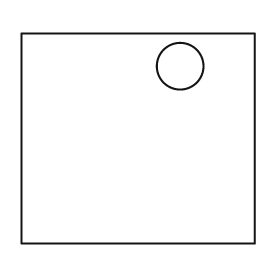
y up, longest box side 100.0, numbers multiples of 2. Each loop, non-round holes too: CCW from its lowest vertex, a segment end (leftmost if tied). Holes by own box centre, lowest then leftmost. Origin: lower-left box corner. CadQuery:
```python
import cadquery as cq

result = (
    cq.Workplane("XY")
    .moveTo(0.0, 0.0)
    .lineTo(100.0, 0.0)
    .lineTo(100.0, 90.0)
    .lineTo(0.0, 90.0)
    .close()
    .moveTo(68.0, 76.0)
    .circle(10.0)
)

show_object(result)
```